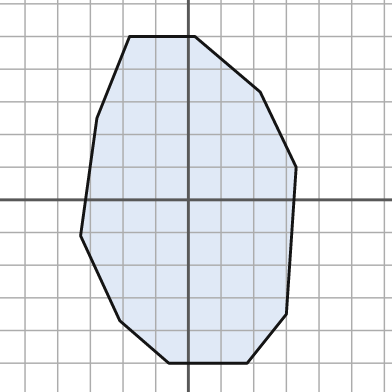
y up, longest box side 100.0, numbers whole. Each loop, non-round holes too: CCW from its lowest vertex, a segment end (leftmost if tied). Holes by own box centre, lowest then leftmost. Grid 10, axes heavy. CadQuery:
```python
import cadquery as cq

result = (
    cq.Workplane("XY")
    .moveTo(-6.0, -50.0)
    .lineTo(18.0, -50.0)
    .lineTo(30.0, -35.0)
    .lineTo(33.0, 10.0)
    .lineTo(22.0, 33.0)
    .lineTo(2.0, 50.0)
    .lineTo(-18.0, 50.0)
    .lineTo(-28.0, 25.0)
    .lineTo(-33.0, -11.0)
    .lineTo(-21.0, -37.0)
    .close()
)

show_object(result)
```